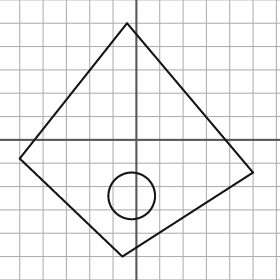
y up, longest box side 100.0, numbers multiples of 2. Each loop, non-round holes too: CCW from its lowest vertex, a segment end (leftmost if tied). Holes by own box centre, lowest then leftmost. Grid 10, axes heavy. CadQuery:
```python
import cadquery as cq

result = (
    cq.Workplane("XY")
    .moveTo(-6.0, -50.0)
    .lineTo(50.0, -14.0)
    .lineTo(-4.0, 50.0)
    .lineTo(-50.0, -8.0)
    .close()
    .moveTo(-2.0, -24.0)
    .circle(10.0)
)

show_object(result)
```